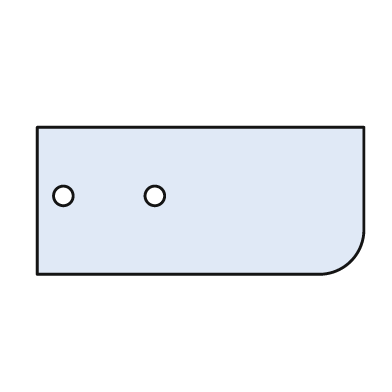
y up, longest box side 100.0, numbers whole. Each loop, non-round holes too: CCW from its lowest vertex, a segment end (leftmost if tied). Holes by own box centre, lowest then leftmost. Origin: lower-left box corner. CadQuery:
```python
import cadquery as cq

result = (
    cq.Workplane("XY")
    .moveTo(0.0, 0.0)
    .lineTo(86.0, 0.0)
    .threePointArc((96.0, 4.0), (100.0, 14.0))
    .lineTo(100.0, 45.0)
    .lineTo(0.0, 45.0)
    .close()
    .moveTo(8.0, 24.0)
    .circle(3.0)
    .moveTo(36.0, 24.0)
    .circle(3.0)
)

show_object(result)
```